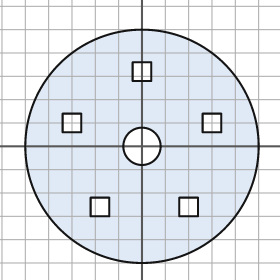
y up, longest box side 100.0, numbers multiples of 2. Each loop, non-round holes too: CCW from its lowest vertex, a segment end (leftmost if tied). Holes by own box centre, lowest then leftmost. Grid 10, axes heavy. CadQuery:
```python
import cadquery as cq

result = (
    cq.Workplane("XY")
    .moveTo(0.0, 0.0)
    .circle(50.0)
    .moveTo(-22.0, -30.0)
    .lineTo(-14.0, -30.0)
    .lineTo(-14.0, -22.0)
    .lineTo(-22.0, -22.0)
    .close()
    .moveTo(16.0, -30.0)
    .lineTo(24.0, -30.0)
    .lineTo(24.0, -22.0)
    .lineTo(16.0, -22.0)
    .close()
    .moveTo(0.0, 0.0)
    .circle(8.0)
    .moveTo(-34.0, 6.0)
    .lineTo(-26.0, 6.0)
    .lineTo(-26.0, 14.0)
    .lineTo(-34.0, 14.0)
    .close()
    .moveTo(26.0, 6.0)
    .lineTo(34.0, 6.0)
    .lineTo(34.0, 14.0)
    .lineTo(26.0, 14.0)
    .close()
    .moveTo(-4.0, 28.0)
    .lineTo(4.0, 28.0)
    .lineTo(4.0, 36.0)
    .lineTo(-4.0, 36.0)
    .close()
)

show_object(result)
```